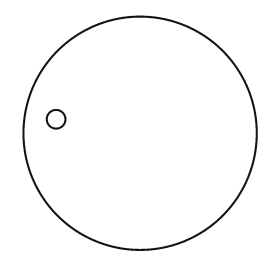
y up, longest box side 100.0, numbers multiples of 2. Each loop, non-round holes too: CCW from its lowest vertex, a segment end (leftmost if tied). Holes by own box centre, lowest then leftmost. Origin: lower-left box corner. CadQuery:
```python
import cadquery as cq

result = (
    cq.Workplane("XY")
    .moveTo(50.0, 50.0)
    .circle(50.0)
    .moveTo(14.0, 56.0)
    .circle(4.0)
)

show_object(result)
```